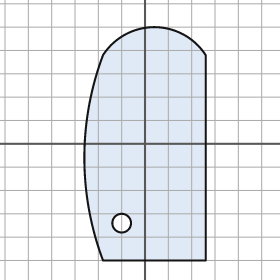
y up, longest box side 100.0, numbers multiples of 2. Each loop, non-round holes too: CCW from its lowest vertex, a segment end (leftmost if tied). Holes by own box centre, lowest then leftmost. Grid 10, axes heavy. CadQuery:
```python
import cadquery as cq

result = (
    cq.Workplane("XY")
    .moveTo(-18.0, -50.0)
    .lineTo(26.0, -50.0)
    .lineTo(26.0, 38.0)
    .threePointArc((4.0, 50.0), (-18.0, 38.0))
    .threePointArc((-26.0, -6.0), (-18.0, -50.0))
    .close()
    .moveTo(-10.0, -34.0)
    .circle(4.0)
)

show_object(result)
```